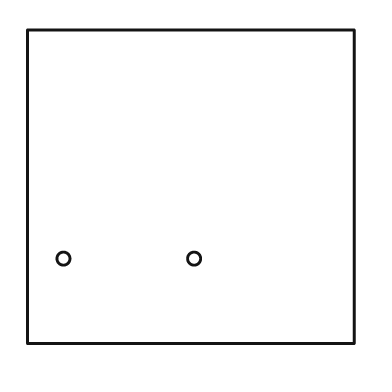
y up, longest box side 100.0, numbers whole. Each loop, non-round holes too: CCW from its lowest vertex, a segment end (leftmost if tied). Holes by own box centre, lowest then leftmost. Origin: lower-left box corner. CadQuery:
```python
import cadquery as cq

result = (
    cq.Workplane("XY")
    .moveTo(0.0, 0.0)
    .lineTo(100.0, 0.0)
    .lineTo(100.0, 96.0)
    .lineTo(0.0, 96.0)
    .close()
    .moveTo(11.0, 26.0)
    .circle(2.0)
    .moveTo(51.0, 26.0)
    .circle(2.0)
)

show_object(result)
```